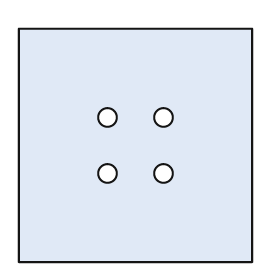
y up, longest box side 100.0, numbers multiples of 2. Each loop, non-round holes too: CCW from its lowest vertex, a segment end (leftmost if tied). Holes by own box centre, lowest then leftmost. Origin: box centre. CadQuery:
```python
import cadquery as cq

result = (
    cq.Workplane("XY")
    .moveTo(-50.0, -50.0)
    .lineTo(50.0, -50.0)
    .lineTo(50.0, 50.0)
    .lineTo(-50.0, 50.0)
    .close()
    .moveTo(-12.0, -12.0)
    .circle(4.0)
    .moveTo(12.0, -12.0)
    .circle(4.0)
    .moveTo(-12.0, 12.0)
    .circle(4.0)
    .moveTo(12.0, 12.0)
    .circle(4.0)
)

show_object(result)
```